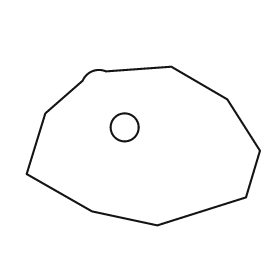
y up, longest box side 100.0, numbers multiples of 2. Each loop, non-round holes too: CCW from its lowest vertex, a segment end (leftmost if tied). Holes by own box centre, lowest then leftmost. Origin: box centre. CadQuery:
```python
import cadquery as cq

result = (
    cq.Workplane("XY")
    .moveTo(6.0, -34.0)
    .lineTo(44.0, -22.0)
    .lineTo(50.0, -2.0)
    .lineTo(36.0, 20.0)
    .lineTo(12.0, 34.0)
    .lineTo(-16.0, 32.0)
    .threePointArc((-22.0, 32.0), (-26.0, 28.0))
    .lineTo(-42.0, 14.0)
    .lineTo(-50.0, -12.0)
    .lineTo(-22.0, -28.0)
    .close()
    .moveTo(-8.0, 8.0)
    .circle(6.0)
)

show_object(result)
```